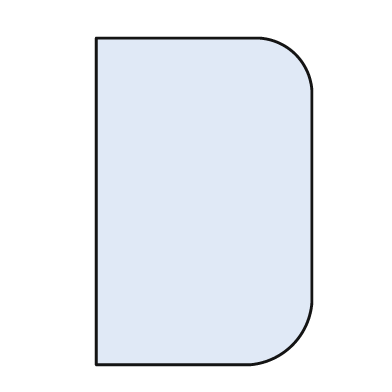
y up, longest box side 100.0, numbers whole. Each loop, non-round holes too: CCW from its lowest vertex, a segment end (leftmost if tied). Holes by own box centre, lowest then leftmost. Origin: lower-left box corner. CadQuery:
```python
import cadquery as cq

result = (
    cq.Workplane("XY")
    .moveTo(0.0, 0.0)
    .lineTo(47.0, 0.0)
    .threePointArc((60.0, 6.0), (66.0, 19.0))
    .lineTo(66.0, 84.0)
    .threePointArc((61.0, 95.0), (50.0, 100.0))
    .lineTo(0.0, 100.0)
    .close()
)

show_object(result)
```